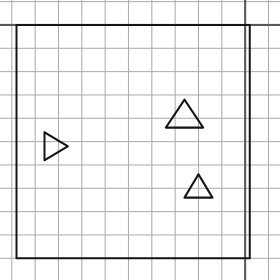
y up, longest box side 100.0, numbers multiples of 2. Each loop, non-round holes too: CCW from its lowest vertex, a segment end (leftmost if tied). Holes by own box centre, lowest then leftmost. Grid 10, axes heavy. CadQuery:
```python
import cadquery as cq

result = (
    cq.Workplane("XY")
    .moveTo(-98.0, -100.0)
    .lineTo(2.0, -100.0)
    .lineTo(2.0, 0.0)
    .lineTo(-98.0, 0.0)
    .close()
    .moveTo(-26.0, -74.0)
    .lineTo(-14.0, -74.0)
    .lineTo(-20.0, -64.0)
    .close()
    .moveTo(-86.0, -58.0)
    .lineTo(-76.0, -52.0)
    .lineTo(-86.0, -46.0)
    .close()
    .moveTo(-34.0, -44.0)
    .lineTo(-18.0, -44.0)
    .lineTo(-26.0, -32.0)
    .close()
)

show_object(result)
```